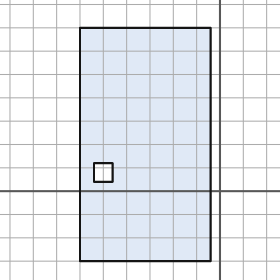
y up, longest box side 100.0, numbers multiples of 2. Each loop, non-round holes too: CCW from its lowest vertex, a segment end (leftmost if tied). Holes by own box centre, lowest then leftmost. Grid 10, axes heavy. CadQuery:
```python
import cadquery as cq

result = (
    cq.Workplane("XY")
    .moveTo(-60.0, -30.0)
    .lineTo(-4.0, -30.0)
    .lineTo(-4.0, 70.0)
    .lineTo(-60.0, 70.0)
    .close()
    .moveTo(-54.0, 4.0)
    .lineTo(-46.0, 4.0)
    .lineTo(-46.0, 12.0)
    .lineTo(-54.0, 12.0)
    .close()
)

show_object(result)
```